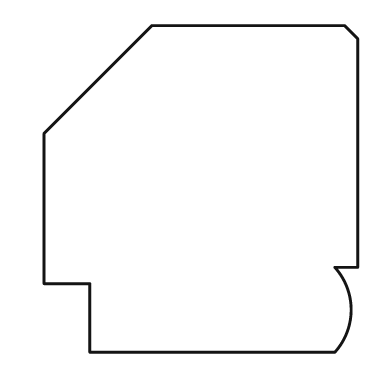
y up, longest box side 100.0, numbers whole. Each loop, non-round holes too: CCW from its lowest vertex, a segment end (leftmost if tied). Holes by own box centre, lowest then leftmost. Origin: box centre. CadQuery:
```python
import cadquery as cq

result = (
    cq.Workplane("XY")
    .moveTo(-34.0, -50.0)
    .lineTo(41.0, -50.0)
    .threePointArc((46.0, -37.0), (41.0, -24.0))
    .lineTo(48.0, -24.0)
    .lineTo(48.0, 46.0)
    .lineTo(44.0, 50.0)
    .lineTo(-15.0, 50.0)
    .lineTo(-48.0, 17.0)
    .lineTo(-48.0, -29.0)
    .lineTo(-34.0, -29.0)
    .close()
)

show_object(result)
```